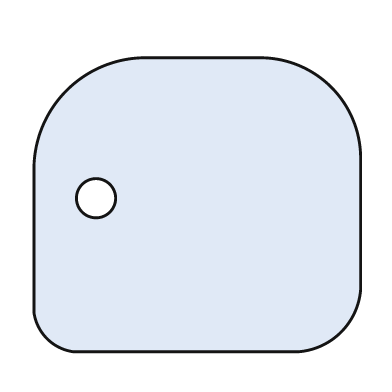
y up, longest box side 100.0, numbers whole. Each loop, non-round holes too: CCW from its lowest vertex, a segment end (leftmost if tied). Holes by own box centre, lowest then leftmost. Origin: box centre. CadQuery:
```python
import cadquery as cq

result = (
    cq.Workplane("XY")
    .moveTo(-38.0, -45.0)
    .lineTo(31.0, -45.0)
    .threePointArc((44.0, -39.0), (50.0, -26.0))
    .lineTo(50.0, 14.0)
    .threePointArc((41.0, 36.0), (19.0, 45.0))
    .lineTo(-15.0, 45.0)
    .threePointArc((-40.0, 35.0), (-50.0, 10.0))
    .lineTo(-50.0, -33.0)
    .threePointArc((-46.0, -41.0), (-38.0, -45.0))
    .close()
    .moveTo(-31.0, 2.0)
    .circle(6.0)
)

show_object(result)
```